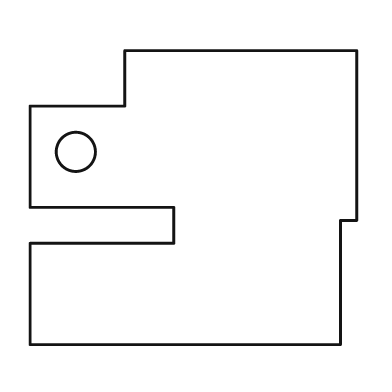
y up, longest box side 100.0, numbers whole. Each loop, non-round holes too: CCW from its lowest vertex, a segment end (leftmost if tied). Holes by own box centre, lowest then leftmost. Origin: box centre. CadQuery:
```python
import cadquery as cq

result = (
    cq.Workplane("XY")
    .moveTo(-50.0, -45.0)
    .lineTo(45.0, -45.0)
    .lineTo(45.0, -7.0)
    .lineTo(50.0, -7.0)
    .lineTo(50.0, 45.0)
    .lineTo(-21.0, 45.0)
    .lineTo(-21.0, 28.0)
    .lineTo(-50.0, 28.0)
    .lineTo(-50.0, -3.0)
    .lineTo(-6.0, -3.0)
    .lineTo(-6.0, -14.0)
    .lineTo(-50.0, -14.0)
    .close()
    .moveTo(-36.0, 14.0)
    .circle(6.0)
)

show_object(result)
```